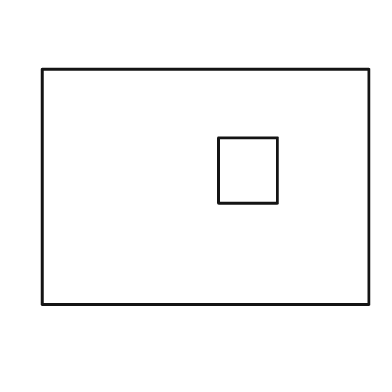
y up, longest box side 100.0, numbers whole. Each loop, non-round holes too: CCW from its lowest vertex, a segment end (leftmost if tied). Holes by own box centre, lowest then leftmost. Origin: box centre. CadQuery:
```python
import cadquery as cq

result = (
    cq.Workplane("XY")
    .moveTo(-50.0, -36.0)
    .lineTo(50.0, -36.0)
    .lineTo(50.0, 36.0)
    .lineTo(-50.0, 36.0)
    .close()
    .moveTo(4.0, -5.0)
    .lineTo(22.0, -5.0)
    .lineTo(22.0, 15.0)
    .lineTo(4.0, 15.0)
    .close()
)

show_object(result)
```